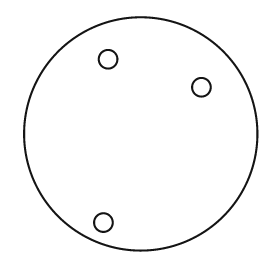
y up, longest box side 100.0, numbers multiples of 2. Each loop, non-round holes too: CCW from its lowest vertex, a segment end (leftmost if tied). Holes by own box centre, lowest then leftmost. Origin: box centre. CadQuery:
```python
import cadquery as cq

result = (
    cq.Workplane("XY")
    .moveTo(0.0, 0.0)
    .circle(50.0)
    .moveTo(-16.0, -38.0)
    .circle(4.0)
    .moveTo(26.0, 20.0)
    .circle(4.0)
    .moveTo(-14.0, 32.0)
    .circle(4.0)
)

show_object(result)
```